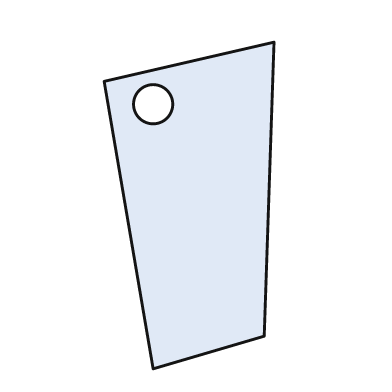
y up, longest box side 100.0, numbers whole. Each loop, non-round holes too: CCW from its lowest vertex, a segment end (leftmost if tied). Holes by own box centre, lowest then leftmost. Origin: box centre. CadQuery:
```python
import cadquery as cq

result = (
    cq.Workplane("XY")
    .moveTo(-11.0, -50.0)
    .lineTo(23.0, -40.0)
    .lineTo(26.0, 50.0)
    .lineTo(-26.0, 38.0)
    .close()
    .moveTo(-11.0, 31.0)
    .circle(6.0)
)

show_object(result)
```